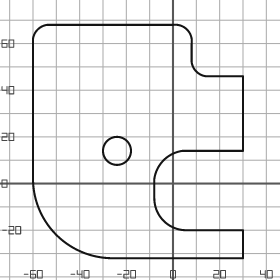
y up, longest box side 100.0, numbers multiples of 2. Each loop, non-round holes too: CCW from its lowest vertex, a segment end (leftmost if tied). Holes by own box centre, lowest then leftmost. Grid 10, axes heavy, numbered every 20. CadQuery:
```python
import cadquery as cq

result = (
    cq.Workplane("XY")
    .moveTo(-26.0, -32.0)
    .lineTo(30.0, -32.0)
    .lineTo(30.0, -20.0)
    .lineTo(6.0, -20.0)
    .threePointArc((-4.0, -16.0), (-8.0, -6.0))
    .lineTo(-8.0, 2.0)
    .threePointArc((-4.0, 10.0), (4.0, 14.0))
    .lineTo(30.0, 14.0)
    .lineTo(30.0, 46.0)
    .lineTo(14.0, 46.0)
    .threePointArc((10.0, 48.0), (8.0, 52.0))
    .lineTo(8.0, 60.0)
    .threePointArc((6.0, 66.0), (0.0, 68.0))
    .lineTo(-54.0, 68.0)
    .threePointArc((-58.0, 66.0), (-60.0, 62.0))
    .lineTo(-60.0, 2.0)
    .threePointArc((-50.0, -22.0), (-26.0, -32.0))
    .close()
    .moveTo(-24.0, 14.0)
    .circle(6.0)
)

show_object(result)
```